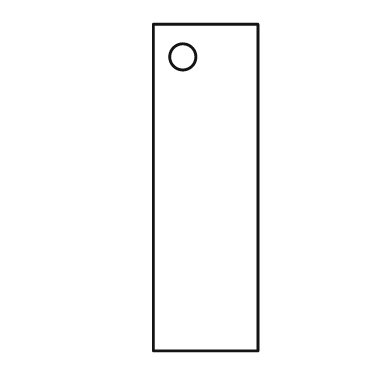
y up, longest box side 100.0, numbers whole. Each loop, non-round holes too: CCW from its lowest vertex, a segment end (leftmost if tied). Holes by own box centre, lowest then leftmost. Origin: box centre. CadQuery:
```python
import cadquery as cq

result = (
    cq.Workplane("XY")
    .moveTo(-16.0, -50.0)
    .lineTo(16.0, -50.0)
    .lineTo(16.0, 50.0)
    .lineTo(-16.0, 50.0)
    .close()
    .moveTo(-7.0, 40.0)
    .circle(4.0)
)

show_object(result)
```